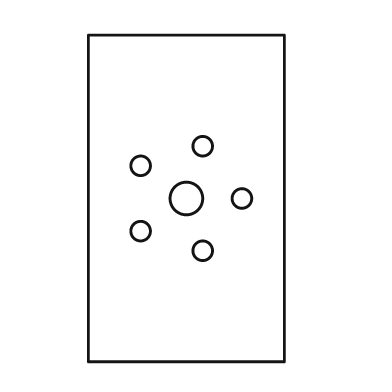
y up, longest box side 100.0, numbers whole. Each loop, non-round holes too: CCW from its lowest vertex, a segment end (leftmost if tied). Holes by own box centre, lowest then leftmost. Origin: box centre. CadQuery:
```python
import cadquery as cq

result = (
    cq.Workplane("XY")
    .moveTo(-30.0, -50.0)
    .lineTo(30.0, -50.0)
    .lineTo(30.0, 50.0)
    .lineTo(-30.0, 50.0)
    .close()
    .moveTo(5.0, -16.0)
    .circle(3.0)
    .moveTo(-14.0, -10.0)
    .circle(3.0)
    .moveTo(0.0, 0.0)
    .circle(5.0)
    .moveTo(17.0, 0.0)
    .circle(3.0)
    .moveTo(-14.0, 10.0)
    .circle(3.0)
    .moveTo(5.0, 16.0)
    .circle(3.0)
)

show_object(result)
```